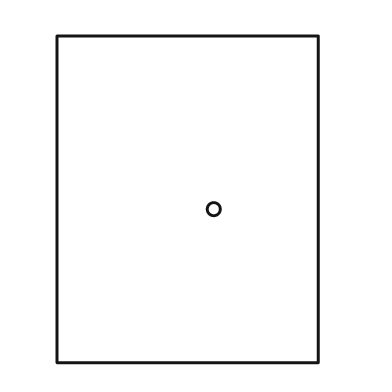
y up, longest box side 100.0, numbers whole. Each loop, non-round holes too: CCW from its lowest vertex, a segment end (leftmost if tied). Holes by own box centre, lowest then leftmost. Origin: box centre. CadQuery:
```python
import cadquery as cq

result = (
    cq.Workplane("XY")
    .moveTo(-40.0, -50.0)
    .lineTo(40.0, -50.0)
    .lineTo(40.0, 50.0)
    .lineTo(-40.0, 50.0)
    .close()
    .moveTo(8.0, -3.0)
    .circle(2.0)
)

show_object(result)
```